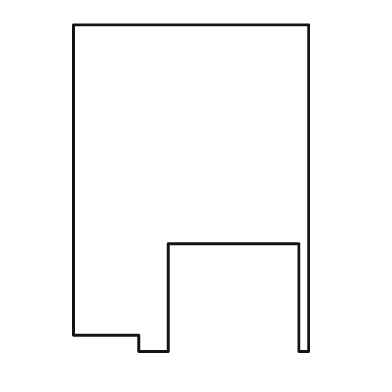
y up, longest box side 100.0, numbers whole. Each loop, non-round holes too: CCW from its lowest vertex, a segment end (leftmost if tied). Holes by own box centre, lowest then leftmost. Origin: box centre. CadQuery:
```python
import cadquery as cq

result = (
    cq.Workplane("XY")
    .moveTo(-16.0, -50.0)
    .lineTo(-7.0, -50.0)
    .lineTo(-7.0, -17.0)
    .lineTo(33.0, -17.0)
    .lineTo(33.0, -50.0)
    .lineTo(36.0, -50.0)
    .lineTo(36.0, 50.0)
    .lineTo(-36.0, 50.0)
    .lineTo(-36.0, -45.0)
    .lineTo(-16.0, -45.0)
    .close()
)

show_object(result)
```